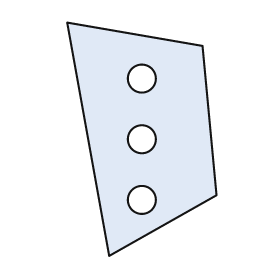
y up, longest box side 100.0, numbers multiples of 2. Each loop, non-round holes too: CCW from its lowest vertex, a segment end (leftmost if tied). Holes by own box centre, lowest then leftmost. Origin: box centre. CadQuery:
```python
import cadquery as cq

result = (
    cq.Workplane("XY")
    .moveTo(-14.0, -50.0)
    .lineTo(32.0, -24.0)
    .lineTo(26.0, 40.0)
    .lineTo(-32.0, 50.0)
    .close()
    .moveTo(0.0, -26.0)
    .circle(6.0)
    .moveTo(0.0, 0.0)
    .circle(6.0)
    .moveTo(0.0, 26.0)
    .circle(6.0)
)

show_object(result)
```